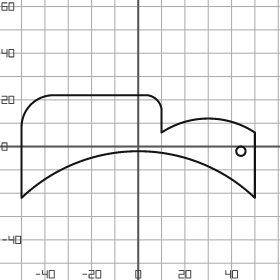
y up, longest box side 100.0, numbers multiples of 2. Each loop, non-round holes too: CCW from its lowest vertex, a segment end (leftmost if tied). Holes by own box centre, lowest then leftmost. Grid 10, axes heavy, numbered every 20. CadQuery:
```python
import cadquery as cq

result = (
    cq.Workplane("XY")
    .moveTo(-50.0, -22.0)
    .threePointArc((0.0, -2.0), (50.0, -22.0))
    .lineTo(50.0, 6.0)
    .threePointArc((30.0, 12.0), (10.0, 6.0))
    .lineTo(10.0, 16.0)
    .threePointArc((8.0, 20.0), (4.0, 22.0))
    .lineTo(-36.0, 22.0)
    .threePointArc((-46.0, 18.0), (-50.0, 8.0))
    .close()
    .moveTo(44.0, -2.0)
    .circle(2.0)
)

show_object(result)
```